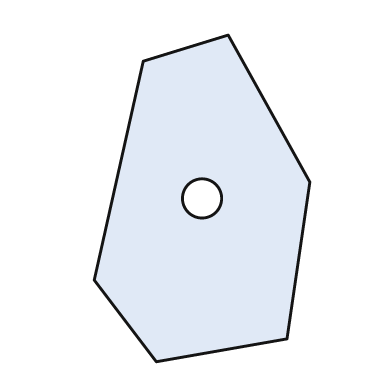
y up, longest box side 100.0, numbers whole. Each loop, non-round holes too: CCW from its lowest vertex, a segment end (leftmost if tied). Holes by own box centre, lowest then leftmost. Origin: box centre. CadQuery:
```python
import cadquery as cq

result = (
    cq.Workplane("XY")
    .moveTo(-14.0, -50.0)
    .lineTo(26.0, -43.0)
    .lineTo(33.0, 5.0)
    .lineTo(8.0, 50.0)
    .lineTo(-18.0, 42.0)
    .lineTo(-33.0, -25.0)
    .close()
    .moveTo(0.0, 0.0)
    .circle(6.0)
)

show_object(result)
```